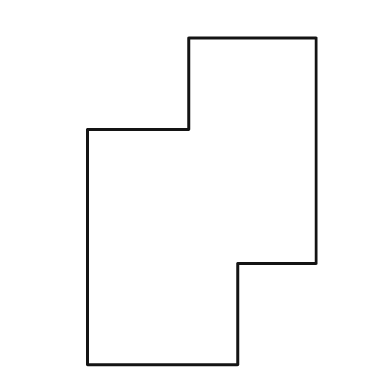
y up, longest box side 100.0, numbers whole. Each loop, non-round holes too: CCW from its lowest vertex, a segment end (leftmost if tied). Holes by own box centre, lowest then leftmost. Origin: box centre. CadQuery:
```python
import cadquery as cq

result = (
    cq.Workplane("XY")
    .moveTo(-35.0, -50.0)
    .lineTo(11.0, -50.0)
    .lineTo(11.0, -19.0)
    .lineTo(35.0, -19.0)
    .lineTo(35.0, 50.0)
    .lineTo(-4.0, 50.0)
    .lineTo(-4.0, 22.0)
    .lineTo(-35.0, 22.0)
    .close()
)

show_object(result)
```